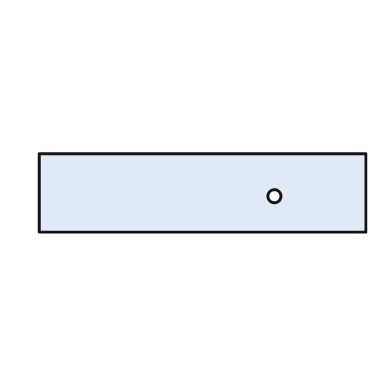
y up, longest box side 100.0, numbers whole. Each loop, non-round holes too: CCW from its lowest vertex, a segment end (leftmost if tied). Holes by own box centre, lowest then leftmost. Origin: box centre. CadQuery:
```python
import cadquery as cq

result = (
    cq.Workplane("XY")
    .moveTo(-50.0, -12.0)
    .lineTo(50.0, -12.0)
    .lineTo(50.0, 12.0)
    .lineTo(-50.0, 12.0)
    .close()
    .moveTo(22.0, -1.0)
    .circle(2.0)
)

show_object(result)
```